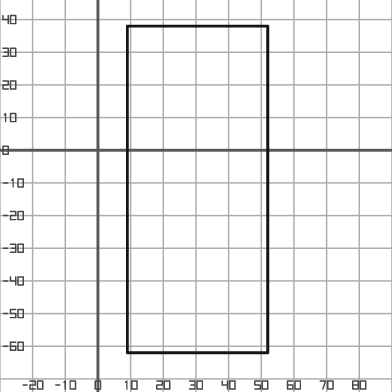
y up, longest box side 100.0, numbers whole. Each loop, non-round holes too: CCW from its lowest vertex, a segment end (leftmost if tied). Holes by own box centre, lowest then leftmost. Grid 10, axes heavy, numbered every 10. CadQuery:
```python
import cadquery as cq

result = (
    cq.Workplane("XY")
    .moveTo(9.0, -62.0)
    .lineTo(52.0, -62.0)
    .lineTo(52.0, 38.0)
    .lineTo(9.0, 38.0)
    .close()
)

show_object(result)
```